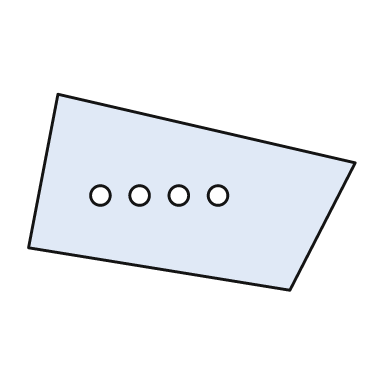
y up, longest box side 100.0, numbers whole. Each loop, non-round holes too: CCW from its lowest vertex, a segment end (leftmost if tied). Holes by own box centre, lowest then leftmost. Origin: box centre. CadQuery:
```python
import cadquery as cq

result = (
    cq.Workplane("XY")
    .moveTo(30.0, -30.0)
    .lineTo(50.0, 9.0)
    .lineTo(-41.0, 30.0)
    .lineTo(-50.0, -17.0)
    .close()
    .moveTo(-28.0, -1.0)
    .circle(3.0)
    .moveTo(-16.0, -1.0)
    .circle(3.0)
    .moveTo(-4.0, -1.0)
    .circle(3.0)
    .moveTo(8.0, -1.0)
    .circle(3.0)
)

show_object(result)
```